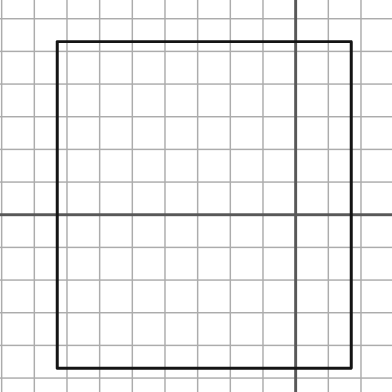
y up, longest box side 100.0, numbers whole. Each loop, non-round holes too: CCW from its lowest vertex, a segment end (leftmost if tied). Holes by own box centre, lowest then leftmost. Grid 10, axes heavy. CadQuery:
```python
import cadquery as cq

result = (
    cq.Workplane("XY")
    .moveTo(-73.0, -47.0)
    .lineTo(17.0, -47.0)
    .lineTo(17.0, 53.0)
    .lineTo(-73.0, 53.0)
    .close()
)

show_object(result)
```